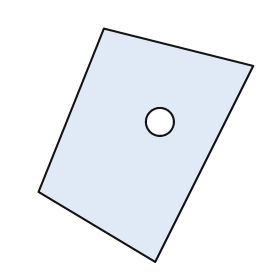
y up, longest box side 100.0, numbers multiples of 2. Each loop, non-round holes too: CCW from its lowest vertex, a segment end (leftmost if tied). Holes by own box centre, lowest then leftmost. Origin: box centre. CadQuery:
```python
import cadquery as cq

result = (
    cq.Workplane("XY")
    .moveTo(4.0, -50.0)
    .lineTo(46.0, 34.0)
    .lineTo(-18.0, 50.0)
    .lineTo(-46.0, -20.0)
    .close()
    .moveTo(6.0, 10.0)
    .circle(6.0)
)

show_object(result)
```